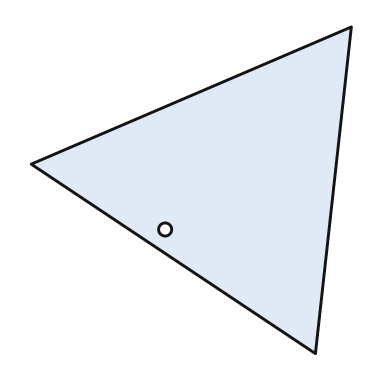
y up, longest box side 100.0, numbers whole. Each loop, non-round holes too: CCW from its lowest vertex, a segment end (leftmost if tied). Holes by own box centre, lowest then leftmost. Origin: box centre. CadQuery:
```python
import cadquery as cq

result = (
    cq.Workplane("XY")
    .moveTo(38.0, -50.0)
    .lineTo(49.0, 50.0)
    .lineTo(-49.0, 8.0)
    .close()
    .moveTo(-8.0, -12.0)
    .circle(2.0)
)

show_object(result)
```